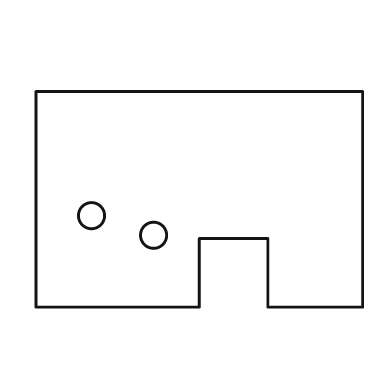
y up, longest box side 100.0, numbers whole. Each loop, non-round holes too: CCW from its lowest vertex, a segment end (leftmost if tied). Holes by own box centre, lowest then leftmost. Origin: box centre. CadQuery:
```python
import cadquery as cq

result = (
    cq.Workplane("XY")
    .moveTo(-50.0, -33.0)
    .lineTo(0.0, -33.0)
    .lineTo(0.0, -12.0)
    .lineTo(21.0, -12.0)
    .lineTo(21.0, -33.0)
    .lineTo(50.0, -33.0)
    .lineTo(50.0, 33.0)
    .lineTo(-50.0, 33.0)
    .close()
    .moveTo(-14.0, -11.0)
    .circle(4.0)
    .moveTo(-33.0, -5.0)
    .circle(4.0)
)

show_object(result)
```